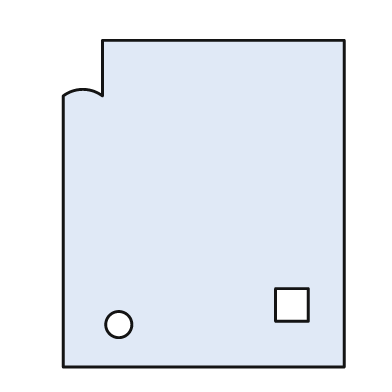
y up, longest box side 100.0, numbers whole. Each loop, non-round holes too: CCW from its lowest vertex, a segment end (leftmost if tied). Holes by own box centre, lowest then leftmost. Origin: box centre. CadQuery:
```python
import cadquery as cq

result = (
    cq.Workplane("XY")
    .moveTo(-43.0, -50.0)
    .lineTo(43.0, -50.0)
    .lineTo(43.0, 50.0)
    .lineTo(-31.0, 50.0)
    .lineTo(-31.0, 33.0)
    .threePointArc((-37.0, 35.0), (-43.0, 33.0))
    .close()
    .moveTo(-26.0, -37.0)
    .circle(4.0)
    .moveTo(22.0, -36.0)
    .lineTo(32.0, -36.0)
    .lineTo(32.0, -26.0)
    .lineTo(22.0, -26.0)
    .close()
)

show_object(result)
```